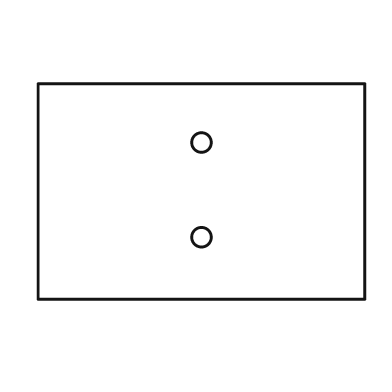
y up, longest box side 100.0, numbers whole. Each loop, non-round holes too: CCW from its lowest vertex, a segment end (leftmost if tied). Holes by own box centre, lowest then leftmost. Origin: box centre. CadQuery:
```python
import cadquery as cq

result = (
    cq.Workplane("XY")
    .moveTo(-50.0, -33.0)
    .lineTo(50.0, -33.0)
    .lineTo(50.0, 33.0)
    .lineTo(-50.0, 33.0)
    .close()
    .moveTo(0.0, -14.0)
    .circle(3.0)
    .moveTo(0.0, 15.0)
    .circle(3.0)
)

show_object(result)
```